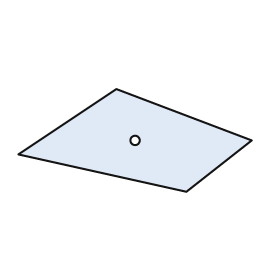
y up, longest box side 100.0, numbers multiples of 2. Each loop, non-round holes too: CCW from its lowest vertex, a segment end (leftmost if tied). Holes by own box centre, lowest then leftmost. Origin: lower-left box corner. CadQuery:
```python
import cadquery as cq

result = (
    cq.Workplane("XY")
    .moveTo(72.0, 0.0)
    .lineTo(100.0, 22.0)
    .lineTo(42.0, 44.0)
    .lineTo(0.0, 16.0)
    .close()
    .moveTo(50.0, 22.0)
    .circle(2.0)
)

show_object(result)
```